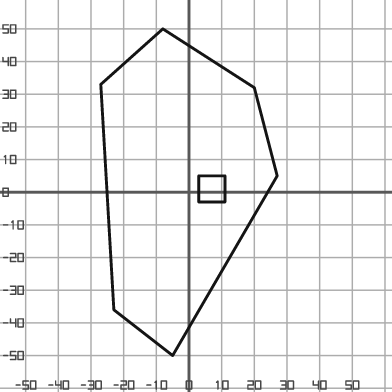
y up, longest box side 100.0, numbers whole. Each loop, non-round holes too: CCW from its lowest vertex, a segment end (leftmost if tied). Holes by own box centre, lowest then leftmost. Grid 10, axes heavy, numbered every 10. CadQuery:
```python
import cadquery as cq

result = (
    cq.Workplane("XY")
    .moveTo(-5.0, -50.0)
    .lineTo(27.0, 5.0)
    .lineTo(20.0, 32.0)
    .lineTo(-8.0, 50.0)
    .lineTo(-27.0, 33.0)
    .lineTo(-23.0, -36.0)
    .close()
    .moveTo(3.0, -3.0)
    .lineTo(11.0, -3.0)
    .lineTo(11.0, 5.0)
    .lineTo(3.0, 5.0)
    .close()
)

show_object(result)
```